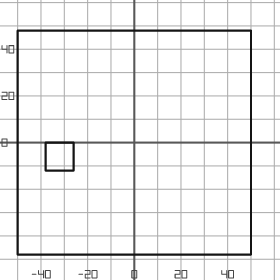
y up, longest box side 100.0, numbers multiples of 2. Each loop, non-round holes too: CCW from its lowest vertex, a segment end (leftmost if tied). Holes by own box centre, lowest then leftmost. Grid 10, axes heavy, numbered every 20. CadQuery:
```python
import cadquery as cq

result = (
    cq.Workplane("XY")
    .moveTo(-50.0, -48.0)
    .lineTo(50.0, -48.0)
    .lineTo(50.0, 48.0)
    .lineTo(-50.0, 48.0)
    .close()
    .moveTo(-38.0, -12.0)
    .lineTo(-26.0, -12.0)
    .lineTo(-26.0, 0.0)
    .lineTo(-38.0, 0.0)
    .close()
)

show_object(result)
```